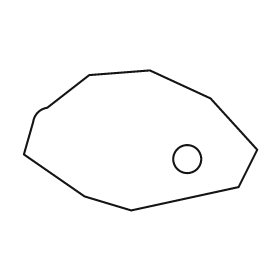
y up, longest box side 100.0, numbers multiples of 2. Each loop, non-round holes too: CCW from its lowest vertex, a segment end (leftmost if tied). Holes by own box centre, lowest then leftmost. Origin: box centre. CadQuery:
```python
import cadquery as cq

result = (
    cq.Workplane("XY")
    .moveTo(-4.0, -30.0)
    .lineTo(42.0, -20.0)
    .lineTo(50.0, -4.0)
    .lineTo(30.0, 18.0)
    .lineTo(4.0, 30.0)
    .lineTo(-22.0, 28.0)
    .lineTo(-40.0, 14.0)
    .threePointArc((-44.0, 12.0), (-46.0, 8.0))
    .lineTo(-50.0, -6.0)
    .lineTo(-24.0, -24.0)
    .close()
    .moveTo(20.0, -8.0)
    .circle(6.0)
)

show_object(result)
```